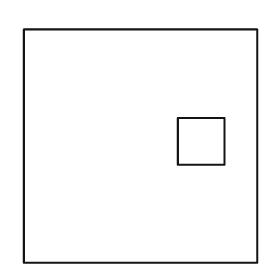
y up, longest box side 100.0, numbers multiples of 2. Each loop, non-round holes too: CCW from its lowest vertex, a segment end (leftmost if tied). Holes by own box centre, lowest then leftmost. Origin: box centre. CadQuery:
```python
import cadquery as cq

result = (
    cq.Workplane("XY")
    .moveTo(-50.0, -50.0)
    .lineTo(50.0, -50.0)
    .lineTo(50.0, 50.0)
    .lineTo(-50.0, 50.0)
    .close()
    .moveTo(16.0, -8.0)
    .lineTo(36.0, -8.0)
    .lineTo(36.0, 12.0)
    .lineTo(16.0, 12.0)
    .close()
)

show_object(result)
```